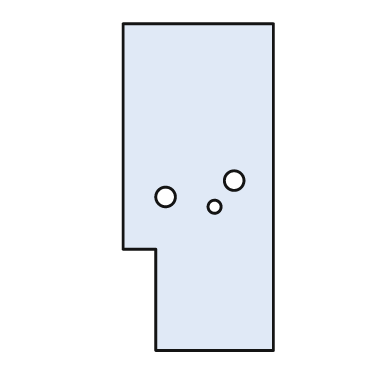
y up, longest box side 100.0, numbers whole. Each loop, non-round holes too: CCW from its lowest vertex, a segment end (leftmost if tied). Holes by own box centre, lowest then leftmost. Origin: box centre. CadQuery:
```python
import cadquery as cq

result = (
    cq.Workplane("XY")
    .moveTo(-13.0, -50.0)
    .lineTo(23.0, -50.0)
    .lineTo(23.0, 50.0)
    .lineTo(-23.0, 50.0)
    .lineTo(-23.0, -19.0)
    .lineTo(-13.0, -19.0)
    .close()
    .moveTo(5.0, -6.0)
    .circle(2.0)
    .moveTo(-10.0, -3.0)
    .circle(3.0)
    .moveTo(11.0, 2.0)
    .circle(3.0)
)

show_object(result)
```